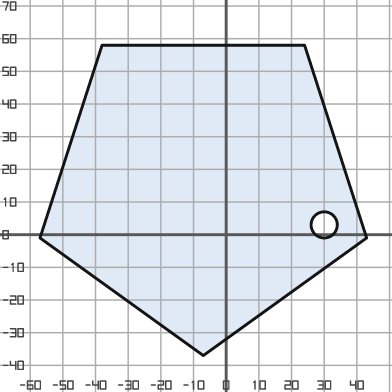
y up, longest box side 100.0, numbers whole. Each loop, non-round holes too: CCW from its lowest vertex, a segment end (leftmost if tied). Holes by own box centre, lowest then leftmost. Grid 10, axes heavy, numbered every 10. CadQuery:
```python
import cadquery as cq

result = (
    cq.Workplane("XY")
    .moveTo(-7.0, -37.0)
    .lineTo(43.0, -1.0)
    .lineTo(24.0, 58.0)
    .lineTo(-38.0, 58.0)
    .lineTo(-57.0, -1.0)
    .close()
    .moveTo(30.0, 3.0)
    .circle(4.0)
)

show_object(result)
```